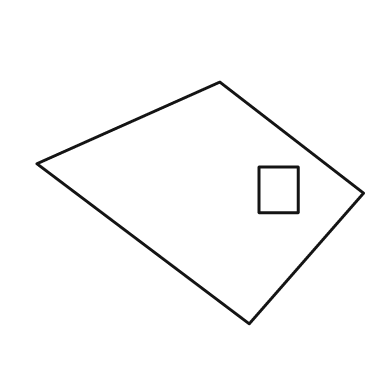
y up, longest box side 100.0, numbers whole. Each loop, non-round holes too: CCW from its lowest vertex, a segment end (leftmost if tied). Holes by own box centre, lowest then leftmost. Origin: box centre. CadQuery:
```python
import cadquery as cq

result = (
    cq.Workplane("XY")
    .moveTo(15.0, -37.0)
    .lineTo(50.0, 3.0)
    .lineTo(6.0, 37.0)
    .lineTo(-50.0, 12.0)
    .close()
    .moveTo(18.0, -3.0)
    .lineTo(30.0, -3.0)
    .lineTo(30.0, 11.0)
    .lineTo(18.0, 11.0)
    .close()
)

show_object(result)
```